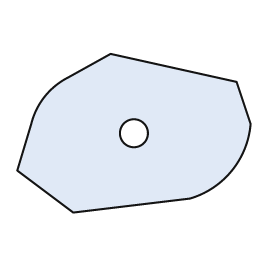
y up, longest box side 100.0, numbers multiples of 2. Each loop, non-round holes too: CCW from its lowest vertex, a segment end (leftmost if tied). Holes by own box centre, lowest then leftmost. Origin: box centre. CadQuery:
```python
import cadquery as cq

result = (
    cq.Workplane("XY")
    .moveTo(-26.0, -34.0)
    .lineTo(24.0, -28.0)
    .threePointArc((42.0, -16.0), (50.0, 4.0))
    .lineTo(44.0, 22.0)
    .lineTo(-10.0, 34.0)
    .lineTo(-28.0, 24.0)
    .threePointArc((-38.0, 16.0), (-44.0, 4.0))
    .lineTo(-50.0, -16.0)
    .close()
    .moveTo(0.0, 0.0)
    .circle(6.0)
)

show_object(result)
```